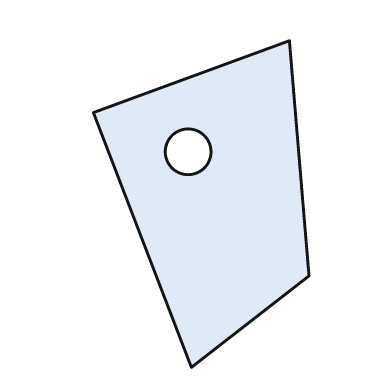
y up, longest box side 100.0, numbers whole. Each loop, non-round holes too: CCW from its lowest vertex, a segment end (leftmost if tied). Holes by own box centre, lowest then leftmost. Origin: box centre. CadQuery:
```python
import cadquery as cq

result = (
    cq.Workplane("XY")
    .moveTo(-3.0, -50.0)
    .lineTo(33.0, -22.0)
    .lineTo(27.0, 50.0)
    .lineTo(-33.0, 28.0)
    .close()
    .moveTo(-4.0, 16.0)
    .circle(7.0)
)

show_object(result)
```